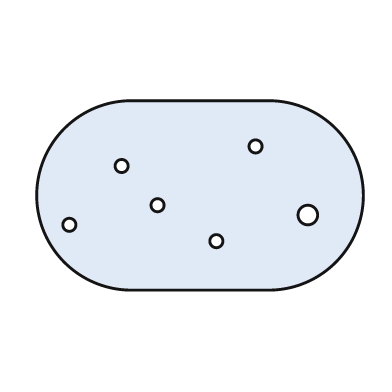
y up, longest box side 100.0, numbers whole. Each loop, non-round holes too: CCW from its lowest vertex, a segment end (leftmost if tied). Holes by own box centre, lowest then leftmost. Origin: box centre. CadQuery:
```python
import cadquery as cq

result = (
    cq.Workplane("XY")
    .moveTo(-21.0, -29.0)
    .lineTo(21.0, -29.0)
    .threePointArc((50.0, 0.0), (21.0, 29.0))
    .lineTo(-21.0, 29.0)
    .threePointArc((-50.0, 0.0), (-21.0, -29.0))
    .close()
    .moveTo(5.0, -14.0)
    .circle(2.0)
    .moveTo(-40.0, -9.0)
    .circle(2.0)
    .moveTo(33.0, -6.0)
    .circle(3.0)
    .moveTo(-13.0, -3.0)
    .circle(2.0)
    .moveTo(-24.0, 9.0)
    .circle(2.0)
    .moveTo(17.0, 15.0)
    .circle(2.0)
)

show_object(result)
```